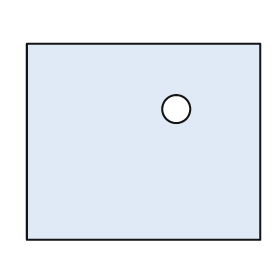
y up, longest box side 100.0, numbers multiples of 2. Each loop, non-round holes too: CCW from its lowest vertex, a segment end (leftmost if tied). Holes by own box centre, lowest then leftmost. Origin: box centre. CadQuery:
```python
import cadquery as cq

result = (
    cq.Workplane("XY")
    .moveTo(-50.0, -42.0)
    .lineTo(50.0, -42.0)
    .lineTo(50.0, 42.0)
    .lineTo(-50.0, 42.0)
    .close()
    .moveTo(14.0, 14.0)
    .circle(6.0)
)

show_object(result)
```